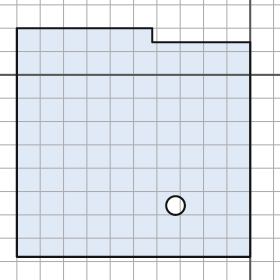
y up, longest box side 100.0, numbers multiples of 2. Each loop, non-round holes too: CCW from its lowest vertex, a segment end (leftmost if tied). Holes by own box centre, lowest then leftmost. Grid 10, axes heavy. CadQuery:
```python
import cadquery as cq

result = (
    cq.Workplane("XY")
    .moveTo(-100.0, -78.0)
    .lineTo(0.0, -78.0)
    .lineTo(0.0, 14.0)
    .lineTo(-42.0, 14.0)
    .lineTo(-42.0, 20.0)
    .lineTo(-100.0, 20.0)
    .close()
    .moveTo(-32.0, -56.0)
    .circle(4.0)
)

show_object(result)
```